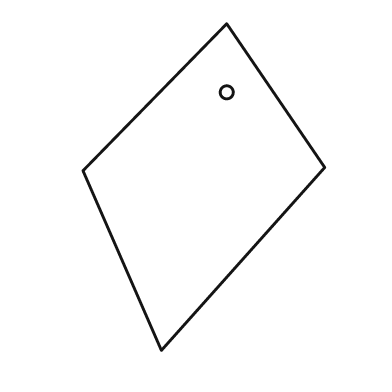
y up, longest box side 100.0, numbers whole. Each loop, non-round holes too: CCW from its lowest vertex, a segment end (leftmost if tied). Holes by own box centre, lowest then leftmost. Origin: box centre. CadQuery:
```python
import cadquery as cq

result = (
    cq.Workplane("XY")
    .moveTo(-13.0, -50.0)
    .lineTo(37.0, 6.0)
    .lineTo(7.0, 50.0)
    .lineTo(-37.0, 5.0)
    .close()
    .moveTo(7.0, 29.0)
    .circle(2.0)
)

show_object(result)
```